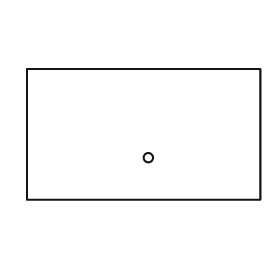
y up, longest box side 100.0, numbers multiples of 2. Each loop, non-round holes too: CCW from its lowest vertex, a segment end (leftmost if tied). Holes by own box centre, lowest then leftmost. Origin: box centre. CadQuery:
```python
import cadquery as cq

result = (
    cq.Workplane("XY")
    .moveTo(-50.0, -28.0)
    .lineTo(50.0, -28.0)
    .lineTo(50.0, 28.0)
    .lineTo(-50.0, 28.0)
    .close()
    .moveTo(2.0, -10.0)
    .circle(2.0)
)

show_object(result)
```